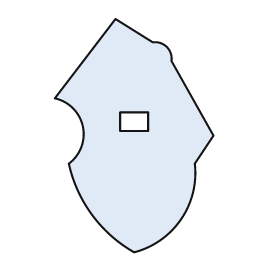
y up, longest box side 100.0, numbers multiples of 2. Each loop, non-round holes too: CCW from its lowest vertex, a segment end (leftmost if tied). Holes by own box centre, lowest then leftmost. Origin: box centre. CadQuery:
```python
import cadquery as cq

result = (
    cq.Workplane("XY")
    .moveTo(0.0, -50.0)
    .threePointArc((20.0, -36.0), (26.0, -12.0))
    .lineTo(34.0, 0.0)
    .lineTo(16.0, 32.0)
    .threePointArc((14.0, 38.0), (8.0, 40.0))
    .lineTo(-8.0, 50.0)
    .lineTo(-34.0, 16.0)
    .threePointArc((-22.0, 4.0), (-28.0, -12.0))
    .threePointArc((-18.0, -34.0), (0.0, -50.0))
    .close()
    .moveTo(-6.0, 2.0)
    .lineTo(6.0, 2.0)
    .lineTo(6.0, 10.0)
    .lineTo(-6.0, 10.0)
    .close()
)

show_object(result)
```